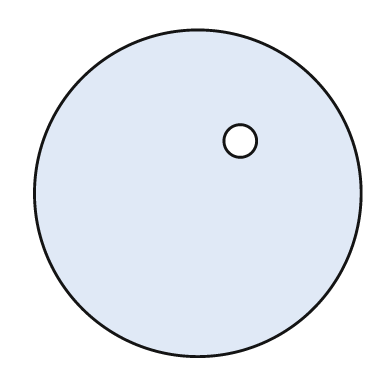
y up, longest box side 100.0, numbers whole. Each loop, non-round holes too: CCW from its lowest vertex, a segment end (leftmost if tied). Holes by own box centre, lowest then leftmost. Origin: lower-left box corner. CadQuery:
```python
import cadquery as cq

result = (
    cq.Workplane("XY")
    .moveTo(50.0, 50.0)
    .circle(50.0)
    .moveTo(63.0, 66.0)
    .circle(5.0)
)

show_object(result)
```